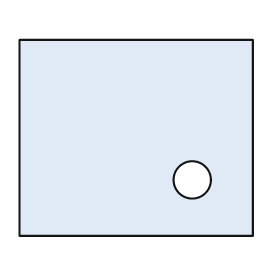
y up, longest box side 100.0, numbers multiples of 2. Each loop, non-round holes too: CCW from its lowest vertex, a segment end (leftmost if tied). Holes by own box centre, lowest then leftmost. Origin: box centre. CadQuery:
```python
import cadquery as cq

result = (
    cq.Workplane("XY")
    .moveTo(-50.0, -42.0)
    .lineTo(50.0, -42.0)
    .lineTo(50.0, 42.0)
    .lineTo(-50.0, 42.0)
    .close()
    .moveTo(24.0, -18.0)
    .circle(8.0)
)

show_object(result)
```